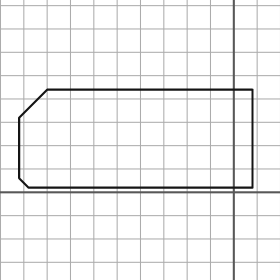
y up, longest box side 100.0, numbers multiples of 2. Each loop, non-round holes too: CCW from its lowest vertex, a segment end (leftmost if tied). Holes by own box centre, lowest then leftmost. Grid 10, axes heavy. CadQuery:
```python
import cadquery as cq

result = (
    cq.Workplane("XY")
    .moveTo(-88.0, 2.0)
    .lineTo(8.0, 2.0)
    .lineTo(8.0, 44.0)
    .lineTo(-80.0, 44.0)
    .lineTo(-92.0, 32.0)
    .lineTo(-92.0, 6.0)
    .close()
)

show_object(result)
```